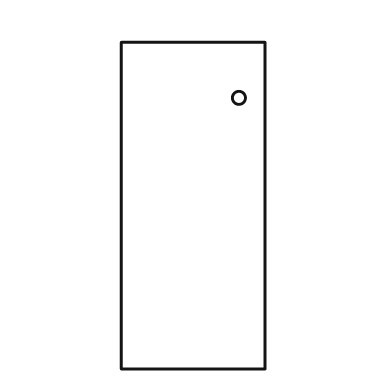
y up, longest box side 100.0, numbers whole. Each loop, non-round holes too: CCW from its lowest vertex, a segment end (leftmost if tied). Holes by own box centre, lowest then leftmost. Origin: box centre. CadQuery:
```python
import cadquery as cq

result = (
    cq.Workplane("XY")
    .moveTo(-22.0, -50.0)
    .lineTo(22.0, -50.0)
    .lineTo(22.0, 50.0)
    .lineTo(-22.0, 50.0)
    .close()
    .moveTo(14.0, 33.0)
    .circle(2.0)
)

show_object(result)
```